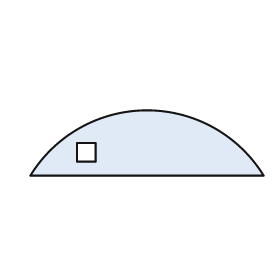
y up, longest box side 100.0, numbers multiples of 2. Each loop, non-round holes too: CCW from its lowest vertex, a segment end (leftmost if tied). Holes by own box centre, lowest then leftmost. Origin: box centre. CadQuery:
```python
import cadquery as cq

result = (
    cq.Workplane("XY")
    .moveTo(-50.0, -14.0)
    .lineTo(50.0, -14.0)
    .threePointArc((0.0, 14.0), (-50.0, -14.0))
    .close()
    .moveTo(-30.0, -8.0)
    .lineTo(-22.0, -8.0)
    .lineTo(-22.0, 0.0)
    .lineTo(-30.0, 0.0)
    .close()
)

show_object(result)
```